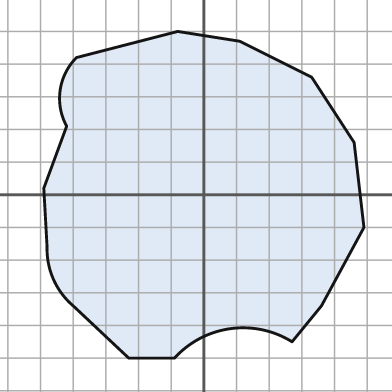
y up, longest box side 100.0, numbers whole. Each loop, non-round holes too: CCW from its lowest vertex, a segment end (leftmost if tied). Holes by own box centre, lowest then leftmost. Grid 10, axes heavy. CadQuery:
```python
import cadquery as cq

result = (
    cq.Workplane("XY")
    .moveTo(-23.0, -50.0)
    .lineTo(-9.0, -50.0)
    .threePointArc((8.0, -41.0), (27.0, -45.0))
    .lineTo(36.0, -34.0)
    .lineTo(49.0, -10.0)
    .lineTo(46.0, 16.0)
    .lineTo(33.0, 36.0)
    .lineTo(11.0, 47.0)
    .lineTo(-8.0, 50.0)
    .lineTo(-39.0, 42.0)
    .threePointArc((-44.0, 32.0), (-42.0, 21.0))
    .lineTo(-49.0, 2.0)
    .lineTo(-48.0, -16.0)
    .threePointArc((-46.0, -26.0), (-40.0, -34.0))
    .close()
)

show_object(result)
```